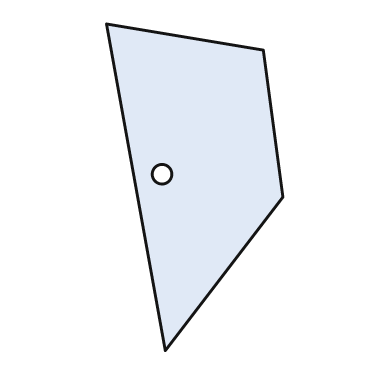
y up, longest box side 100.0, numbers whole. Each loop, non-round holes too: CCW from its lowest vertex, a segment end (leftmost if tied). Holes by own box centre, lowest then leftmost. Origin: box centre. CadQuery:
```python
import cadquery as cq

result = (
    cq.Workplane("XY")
    .moveTo(-9.0, -50.0)
    .lineTo(27.0, -3.0)
    .lineTo(21.0, 42.0)
    .lineTo(-27.0, 50.0)
    .close()
    .moveTo(-10.0, 4.0)
    .circle(3.0)
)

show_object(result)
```